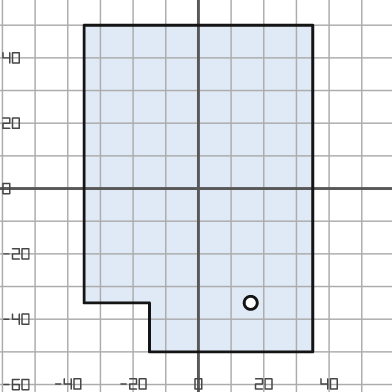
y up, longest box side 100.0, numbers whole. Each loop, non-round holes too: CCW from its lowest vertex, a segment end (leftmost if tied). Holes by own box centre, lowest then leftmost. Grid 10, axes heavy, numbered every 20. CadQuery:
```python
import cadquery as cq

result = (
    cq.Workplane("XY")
    .moveTo(-15.0, -50.0)
    .lineTo(35.0, -50.0)
    .lineTo(35.0, 50.0)
    .lineTo(-35.0, 50.0)
    .lineTo(-35.0, -35.0)
    .lineTo(-15.0, -35.0)
    .close()
    .moveTo(16.0, -35.0)
    .circle(2.0)
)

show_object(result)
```